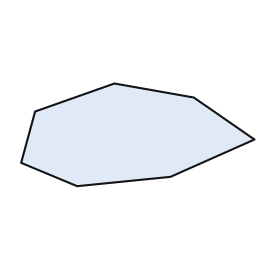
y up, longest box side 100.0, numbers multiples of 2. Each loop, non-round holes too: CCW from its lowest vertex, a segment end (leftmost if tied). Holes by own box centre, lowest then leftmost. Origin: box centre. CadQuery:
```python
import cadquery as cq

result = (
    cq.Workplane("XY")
    .moveTo(-26.0, -22.0)
    .lineTo(14.0, -18.0)
    .lineTo(50.0, -2.0)
    .lineTo(24.0, 16.0)
    .lineTo(-10.0, 22.0)
    .lineTo(-44.0, 10.0)
    .lineTo(-50.0, -12.0)
    .close()
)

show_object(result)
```